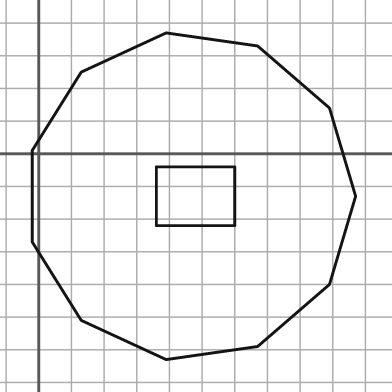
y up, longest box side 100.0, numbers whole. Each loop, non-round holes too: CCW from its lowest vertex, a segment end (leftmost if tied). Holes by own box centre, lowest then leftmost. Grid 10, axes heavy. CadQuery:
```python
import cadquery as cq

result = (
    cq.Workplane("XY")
    .moveTo(39.0, -63.0)
    .lineTo(67.0, -59.0)
    .lineTo(89.0, -40.0)
    .lineTo(97.0, -13.0)
    .lineTo(89.0, 14.0)
    .lineTo(67.0, 33.0)
    .lineTo(39.0, 37.0)
    .lineTo(13.0, 25.0)
    .lineTo(-2.0, 1.0)
    .lineTo(-2.0, -27.0)
    .lineTo(13.0, -51.0)
    .close()
    .moveTo(36.0, -22.0)
    .lineTo(60.0, -22.0)
    .lineTo(60.0, -4.0)
    .lineTo(36.0, -4.0)
    .close()
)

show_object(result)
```